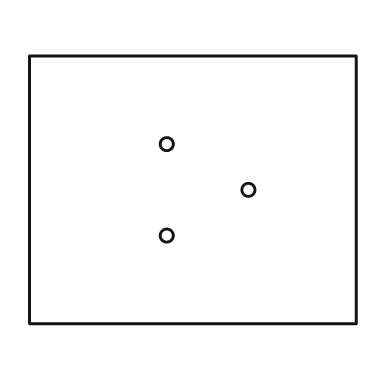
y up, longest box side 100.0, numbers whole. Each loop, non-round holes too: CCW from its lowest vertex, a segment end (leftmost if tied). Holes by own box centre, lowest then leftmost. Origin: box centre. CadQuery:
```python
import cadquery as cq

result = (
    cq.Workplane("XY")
    .moveTo(-50.0, -41.0)
    .lineTo(50.0, -41.0)
    .lineTo(50.0, 41.0)
    .lineTo(-50.0, 41.0)
    .close()
    .moveTo(-8.0, -14.0)
    .circle(2.0)
    .moveTo(17.0, 0.0)
    .circle(2.0)
    .moveTo(-8.0, 14.0)
    .circle(2.0)
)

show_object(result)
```